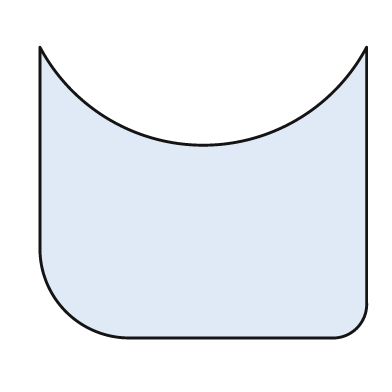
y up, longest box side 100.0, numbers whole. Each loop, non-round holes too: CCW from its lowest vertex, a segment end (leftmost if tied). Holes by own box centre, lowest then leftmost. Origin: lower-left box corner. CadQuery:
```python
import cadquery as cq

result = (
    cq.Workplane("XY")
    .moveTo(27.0, 0.0)
    .lineTo(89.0, 0.0)
    .threePointArc((97.0, 3.0), (100.0, 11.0))
    .lineTo(100.0, 89.0)
    .threePointArc((50.0, 59.0), (0.0, 89.0))
    .lineTo(0.0, 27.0)
    .threePointArc((8.0, 8.0), (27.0, 0.0))
    .close()
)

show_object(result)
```